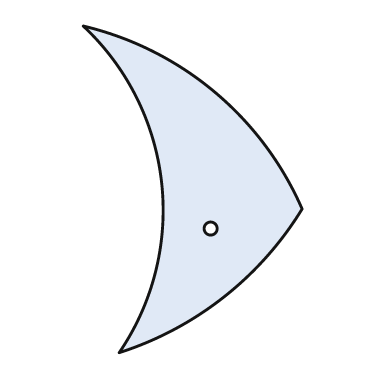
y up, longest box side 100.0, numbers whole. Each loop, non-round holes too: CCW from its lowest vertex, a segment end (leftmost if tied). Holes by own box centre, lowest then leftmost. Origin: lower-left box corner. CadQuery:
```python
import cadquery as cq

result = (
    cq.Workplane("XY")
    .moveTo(11.0, 0.0)
    .threePointArc((43.0, 17.0), (67.0, 44.0))
    .threePointArc((40.0, 80.0), (0.0, 100.0))
    .threePointArc((24.0, 52.0), (11.0, 0.0))
    .close()
    .moveTo(39.0, 38.0)
    .circle(2.0)
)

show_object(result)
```